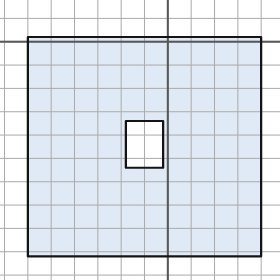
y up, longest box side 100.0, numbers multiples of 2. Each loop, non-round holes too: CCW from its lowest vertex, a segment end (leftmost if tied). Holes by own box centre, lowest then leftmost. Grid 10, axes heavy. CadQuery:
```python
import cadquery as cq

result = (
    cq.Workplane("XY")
    .moveTo(-60.0, -92.0)
    .lineTo(40.0, -92.0)
    .lineTo(40.0, 2.0)
    .lineTo(-60.0, 2.0)
    .close()
    .moveTo(-18.0, -54.0)
    .lineTo(-2.0, -54.0)
    .lineTo(-2.0, -34.0)
    .lineTo(-18.0, -34.0)
    .close()
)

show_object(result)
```